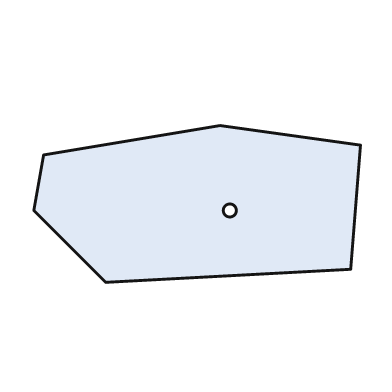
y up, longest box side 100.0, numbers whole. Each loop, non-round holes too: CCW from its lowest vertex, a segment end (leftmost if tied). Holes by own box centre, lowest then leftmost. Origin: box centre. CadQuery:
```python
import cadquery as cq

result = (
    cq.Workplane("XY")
    .moveTo(-28.0, -24.0)
    .lineTo(47.0, -20.0)
    .lineTo(50.0, 18.0)
    .lineTo(7.0, 24.0)
    .lineTo(-47.0, 15.0)
    .lineTo(-50.0, -2.0)
    .close()
    .moveTo(10.0, -2.0)
    .circle(2.0)
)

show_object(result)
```